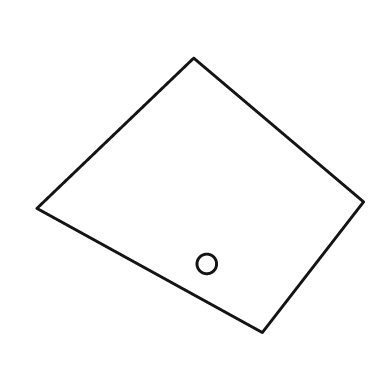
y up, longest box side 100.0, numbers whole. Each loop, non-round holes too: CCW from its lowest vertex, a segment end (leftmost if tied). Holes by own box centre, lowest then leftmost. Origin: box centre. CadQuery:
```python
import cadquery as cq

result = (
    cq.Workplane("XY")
    .moveTo(19.0, -42.0)
    .lineTo(50.0, -2.0)
    .lineTo(-2.0, 42.0)
    .lineTo(-50.0, -4.0)
    .close()
    .moveTo(2.0, -21.0)
    .circle(3.0)
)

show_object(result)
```